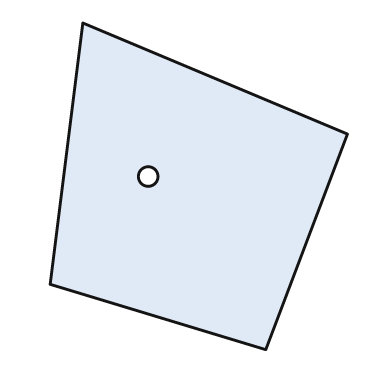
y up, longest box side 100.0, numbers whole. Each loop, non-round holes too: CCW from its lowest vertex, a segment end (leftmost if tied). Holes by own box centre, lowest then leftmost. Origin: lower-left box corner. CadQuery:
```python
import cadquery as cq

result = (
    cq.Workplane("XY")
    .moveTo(66.0, 0.0)
    .lineTo(91.0, 66.0)
    .lineTo(10.0, 100.0)
    .lineTo(0.0, 20.0)
    .close()
    .moveTo(30.0, 53.0)
    .circle(3.0)
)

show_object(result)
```